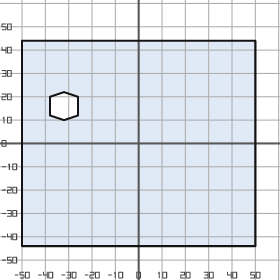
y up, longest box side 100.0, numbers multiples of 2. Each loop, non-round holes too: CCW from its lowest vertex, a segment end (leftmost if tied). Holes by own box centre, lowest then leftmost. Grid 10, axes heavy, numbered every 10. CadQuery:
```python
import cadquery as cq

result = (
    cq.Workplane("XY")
    .moveTo(-50.0, -44.0)
    .lineTo(50.0, -44.0)
    .lineTo(50.0, 44.0)
    .lineTo(-50.0, 44.0)
    .close()
    .moveTo(-32.0, 10.0)
    .lineTo(-26.0, 12.0)
    .lineTo(-26.0, 20.0)
    .lineTo(-32.0, 22.0)
    .lineTo(-38.0, 20.0)
    .lineTo(-38.0, 12.0)
    .close()
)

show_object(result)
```